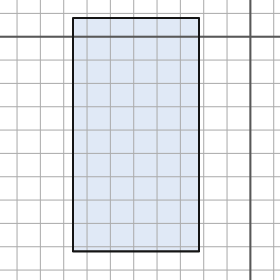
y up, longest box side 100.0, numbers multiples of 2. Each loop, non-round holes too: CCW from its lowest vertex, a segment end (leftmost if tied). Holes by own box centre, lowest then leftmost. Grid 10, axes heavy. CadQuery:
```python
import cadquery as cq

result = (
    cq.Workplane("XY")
    .moveTo(-76.0, -92.0)
    .lineTo(-22.0, -92.0)
    .lineTo(-22.0, 8.0)
    .lineTo(-76.0, 8.0)
    .close()
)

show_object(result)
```